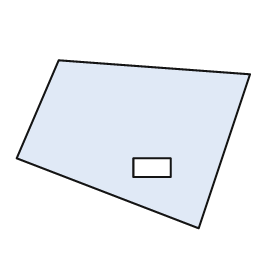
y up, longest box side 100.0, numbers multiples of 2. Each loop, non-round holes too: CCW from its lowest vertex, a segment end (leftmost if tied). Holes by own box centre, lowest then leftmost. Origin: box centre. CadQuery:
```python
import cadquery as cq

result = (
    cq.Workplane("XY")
    .moveTo(28.0, -36.0)
    .lineTo(50.0, 30.0)
    .lineTo(-32.0, 36.0)
    .lineTo(-50.0, -6.0)
    .close()
    .moveTo(0.0, -14.0)
    .lineTo(16.0, -14.0)
    .lineTo(16.0, -6.0)
    .lineTo(0.0, -6.0)
    .close()
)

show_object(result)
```